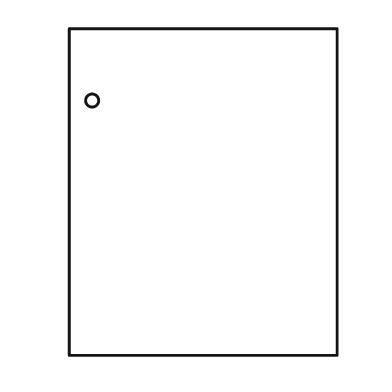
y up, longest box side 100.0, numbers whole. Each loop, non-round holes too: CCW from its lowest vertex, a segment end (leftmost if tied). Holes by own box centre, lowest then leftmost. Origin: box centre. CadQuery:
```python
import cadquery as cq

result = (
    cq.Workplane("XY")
    .moveTo(-41.0, -50.0)
    .lineTo(41.0, -50.0)
    .lineTo(41.0, 50.0)
    .lineTo(-41.0, 50.0)
    .close()
    .moveTo(-34.0, 28.0)
    .circle(2.0)
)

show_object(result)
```